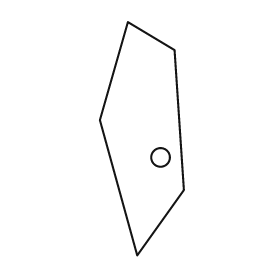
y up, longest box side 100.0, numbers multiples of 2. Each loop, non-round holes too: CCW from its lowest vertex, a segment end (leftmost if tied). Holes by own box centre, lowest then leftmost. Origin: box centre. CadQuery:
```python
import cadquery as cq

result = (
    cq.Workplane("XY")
    .moveTo(-2.0, -50.0)
    .lineTo(18.0, -22.0)
    .lineTo(14.0, 38.0)
    .lineTo(-6.0, 50.0)
    .lineTo(-18.0, 8.0)
    .close()
    .moveTo(8.0, -8.0)
    .circle(4.0)
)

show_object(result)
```